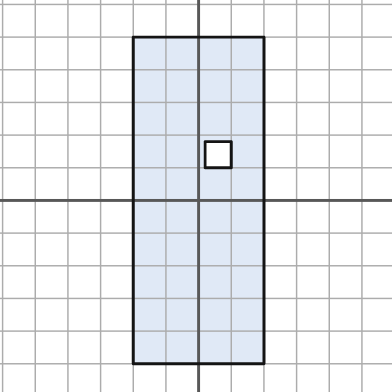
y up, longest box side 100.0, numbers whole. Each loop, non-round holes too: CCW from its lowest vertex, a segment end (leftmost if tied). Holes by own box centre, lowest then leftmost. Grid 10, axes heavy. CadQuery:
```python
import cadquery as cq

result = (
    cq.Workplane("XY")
    .moveTo(-20.0, -50.0)
    .lineTo(20.0, -50.0)
    .lineTo(20.0, 50.0)
    .lineTo(-20.0, 50.0)
    .close()
    .moveTo(2.0, 10.0)
    .lineTo(10.0, 10.0)
    .lineTo(10.0, 18.0)
    .lineTo(2.0, 18.0)
    .close()
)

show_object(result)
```